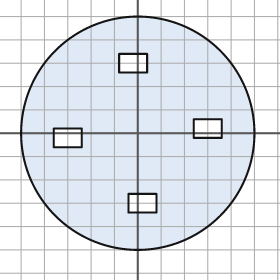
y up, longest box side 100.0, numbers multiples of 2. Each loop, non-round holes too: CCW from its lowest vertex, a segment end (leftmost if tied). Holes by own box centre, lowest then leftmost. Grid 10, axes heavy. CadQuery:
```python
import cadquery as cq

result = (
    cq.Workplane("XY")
    .moveTo(0.0, 0.0)
    .circle(50.0)
    .moveTo(-4.0, -34.0)
    .lineTo(8.0, -34.0)
    .lineTo(8.0, -26.0)
    .lineTo(-4.0, -26.0)
    .close()
    .moveTo(-36.0, -6.0)
    .lineTo(-24.0, -6.0)
    .lineTo(-24.0, 2.0)
    .lineTo(-36.0, 2.0)
    .close()
    .moveTo(24.0, -2.0)
    .lineTo(36.0, -2.0)
    .lineTo(36.0, 6.0)
    .lineTo(24.0, 6.0)
    .close()
    .moveTo(-8.0, 26.0)
    .lineTo(4.0, 26.0)
    .lineTo(4.0, 34.0)
    .lineTo(-8.0, 34.0)
    .close()
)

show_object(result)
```